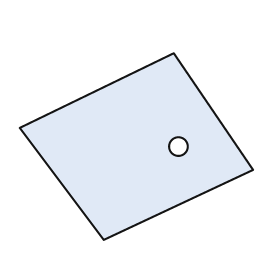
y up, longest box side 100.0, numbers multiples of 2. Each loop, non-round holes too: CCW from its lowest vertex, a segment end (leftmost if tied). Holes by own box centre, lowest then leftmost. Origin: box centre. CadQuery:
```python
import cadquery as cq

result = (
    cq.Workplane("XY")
    .moveTo(-14.0, -40.0)
    .lineTo(50.0, -10.0)
    .lineTo(16.0, 40.0)
    .lineTo(-50.0, 8.0)
    .close()
    .moveTo(18.0, 0.0)
    .circle(4.0)
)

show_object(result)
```